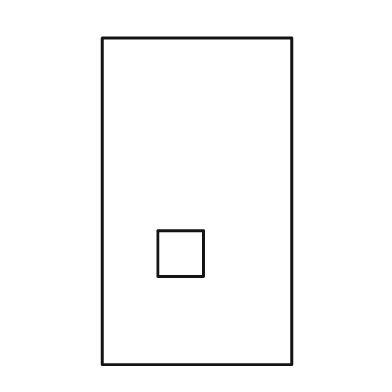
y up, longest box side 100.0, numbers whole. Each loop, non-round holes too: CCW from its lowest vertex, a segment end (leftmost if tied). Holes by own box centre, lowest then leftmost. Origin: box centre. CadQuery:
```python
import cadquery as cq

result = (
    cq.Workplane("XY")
    .moveTo(-29.0, -50.0)
    .lineTo(29.0, -50.0)
    .lineTo(29.0, 50.0)
    .lineTo(-29.0, 50.0)
    .close()
    .moveTo(-12.0, -23.0)
    .lineTo(2.0, -23.0)
    .lineTo(2.0, -9.0)
    .lineTo(-12.0, -9.0)
    .close()
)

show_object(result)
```